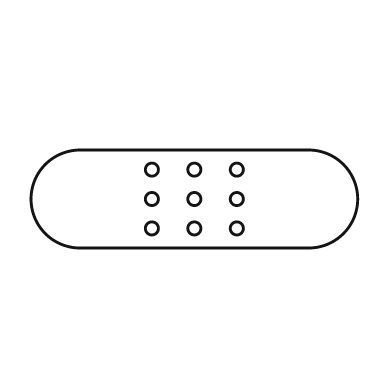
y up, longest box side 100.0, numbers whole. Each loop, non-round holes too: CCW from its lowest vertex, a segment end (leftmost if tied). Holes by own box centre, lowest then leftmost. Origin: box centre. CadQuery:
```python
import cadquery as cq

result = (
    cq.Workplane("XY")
    .moveTo(-35.0, -15.0)
    .lineTo(35.0, -15.0)
    .threePointArc((50.0, 0.0), (35.0, 15.0))
    .lineTo(-35.0, 15.0)
    .threePointArc((-50.0, 0.0), (-35.0, -15.0))
    .close()
    .moveTo(-13.0, -9.0)
    .circle(2.0)
    .moveTo(0.0, -9.0)
    .circle(2.0)
    .moveTo(13.0, -9.0)
    .circle(2.0)
    .moveTo(-13.0, 0.0)
    .circle(2.0)
    .moveTo(0.0, 0.0)
    .circle(2.0)
    .moveTo(13.0, 0.0)
    .circle(2.0)
    .moveTo(-13.0, 9.0)
    .circle(2.0)
    .moveTo(0.0, 9.0)
    .circle(2.0)
    .moveTo(13.0, 9.0)
    .circle(2.0)
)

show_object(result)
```